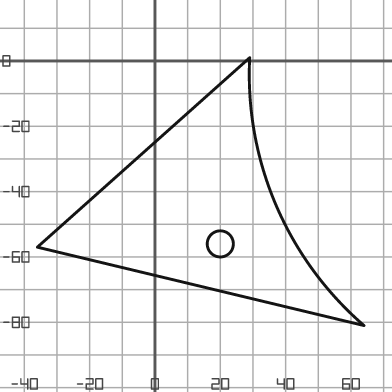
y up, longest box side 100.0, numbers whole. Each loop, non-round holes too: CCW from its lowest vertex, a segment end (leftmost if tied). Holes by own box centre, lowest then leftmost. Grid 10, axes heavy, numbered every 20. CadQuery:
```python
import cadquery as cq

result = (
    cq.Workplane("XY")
    .moveTo(64.0, -81.0)
    .threePointArc((37.0, -44.0), (29.0, 1.0))
    .lineTo(-36.0, -57.0)
    .close()
    .moveTo(20.0, -56.0)
    .circle(4.0)
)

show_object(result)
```